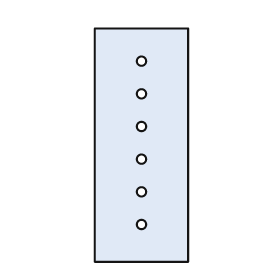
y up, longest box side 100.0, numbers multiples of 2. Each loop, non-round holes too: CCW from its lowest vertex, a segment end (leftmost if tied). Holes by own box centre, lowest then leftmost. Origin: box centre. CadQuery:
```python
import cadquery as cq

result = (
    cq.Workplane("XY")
    .moveTo(-20.0, -50.0)
    .lineTo(20.0, -50.0)
    .lineTo(20.0, 50.0)
    .lineTo(-20.0, 50.0)
    .close()
    .moveTo(0.0, -34.0)
    .circle(2.0)
    .moveTo(0.0, -20.0)
    .circle(2.0)
    .moveTo(0.0, -6.0)
    .circle(2.0)
    .moveTo(0.0, 8.0)
    .circle(2.0)
    .moveTo(0.0, 22.0)
    .circle(2.0)
    .moveTo(0.0, 36.0)
    .circle(2.0)
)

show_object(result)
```